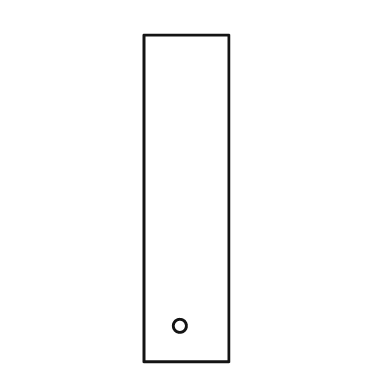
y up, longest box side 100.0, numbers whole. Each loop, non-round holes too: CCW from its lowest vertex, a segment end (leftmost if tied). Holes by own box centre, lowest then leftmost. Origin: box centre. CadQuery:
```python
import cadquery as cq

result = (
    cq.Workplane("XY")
    .moveTo(-13.0, -50.0)
    .lineTo(13.0, -50.0)
    .lineTo(13.0, 50.0)
    .lineTo(-13.0, 50.0)
    .close()
    .moveTo(-2.0, -39.0)
    .circle(2.0)
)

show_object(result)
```